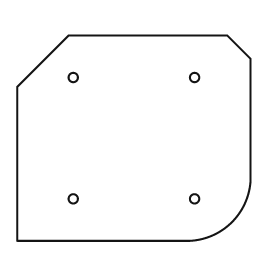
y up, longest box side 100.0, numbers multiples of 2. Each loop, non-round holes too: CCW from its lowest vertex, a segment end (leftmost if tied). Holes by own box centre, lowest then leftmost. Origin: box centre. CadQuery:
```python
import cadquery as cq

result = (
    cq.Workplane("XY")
    .moveTo(-50.0, -44.0)
    .lineTo(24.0, -44.0)
    .threePointArc((42.0, -36.0), (50.0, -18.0))
    .lineTo(50.0, 34.0)
    .lineTo(40.0, 44.0)
    .lineTo(-28.0, 44.0)
    .lineTo(-50.0, 22.0)
    .close()
    .moveTo(-26.0, -26.0)
    .circle(2.0)
    .moveTo(26.0, -26.0)
    .circle(2.0)
    .moveTo(-26.0, 26.0)
    .circle(2.0)
    .moveTo(26.0, 26.0)
    .circle(2.0)
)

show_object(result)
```